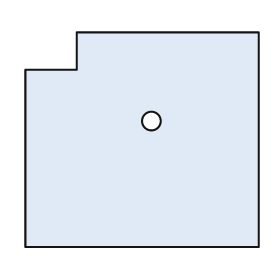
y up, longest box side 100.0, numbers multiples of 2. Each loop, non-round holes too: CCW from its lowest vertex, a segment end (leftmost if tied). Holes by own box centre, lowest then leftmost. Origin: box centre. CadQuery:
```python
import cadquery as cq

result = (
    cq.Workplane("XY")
    .moveTo(-50.0, -46.0)
    .lineTo(50.0, -46.0)
    .lineTo(50.0, 46.0)
    .lineTo(-28.0, 46.0)
    .lineTo(-28.0, 30.0)
    .lineTo(-50.0, 30.0)
    .close()
    .moveTo(4.0, 8.0)
    .circle(4.0)
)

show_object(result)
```